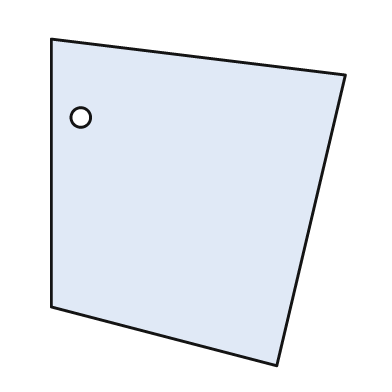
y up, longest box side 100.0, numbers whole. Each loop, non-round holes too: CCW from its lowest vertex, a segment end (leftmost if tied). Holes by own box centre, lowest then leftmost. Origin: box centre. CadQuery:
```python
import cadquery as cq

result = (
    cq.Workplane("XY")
    .moveTo(24.0, -50.0)
    .lineTo(45.0, 39.0)
    .lineTo(-45.0, 50.0)
    .lineTo(-45.0, -32.0)
    .close()
    .moveTo(-36.0, 26.0)
    .circle(3.0)
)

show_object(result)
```